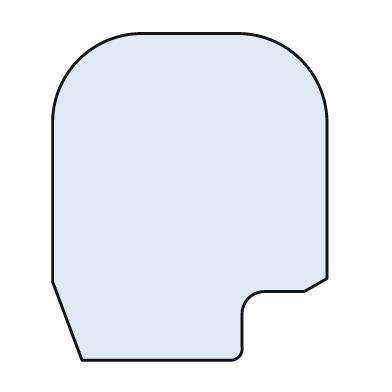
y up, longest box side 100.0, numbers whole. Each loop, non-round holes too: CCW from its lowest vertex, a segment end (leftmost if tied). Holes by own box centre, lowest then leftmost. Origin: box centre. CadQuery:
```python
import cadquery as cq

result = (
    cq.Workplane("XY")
    .moveTo(-33.0, -50.0)
    .lineTo(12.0, -50.0)
    .threePointArc((15.0, -49.0), (16.0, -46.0))
    .lineTo(16.0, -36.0)
    .threePointArc((18.0, -31.0), (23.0, -29.0))
    .lineTo(35.0, -29.0)
    .lineTo(42.0, -25.0)
    .lineTo(42.0, 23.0)
    .threePointArc((34.0, 42.0), (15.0, 50.0))
    .lineTo(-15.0, 50.0)
    .threePointArc((-34.0, 42.0), (-42.0, 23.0))
    .lineTo(-42.0, -26.0)
    .close()
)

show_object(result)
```